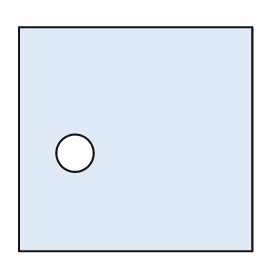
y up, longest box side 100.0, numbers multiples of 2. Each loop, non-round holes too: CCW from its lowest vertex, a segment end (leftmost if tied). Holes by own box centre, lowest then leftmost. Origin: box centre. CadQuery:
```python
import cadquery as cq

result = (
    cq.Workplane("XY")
    .moveTo(-50.0, -48.0)
    .lineTo(50.0, -48.0)
    .lineTo(50.0, 48.0)
    .lineTo(-50.0, 48.0)
    .close()
    .moveTo(-26.0, -6.0)
    .circle(8.0)
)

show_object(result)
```